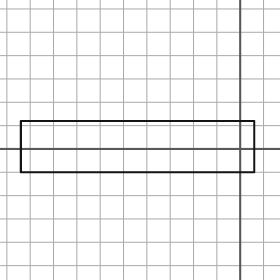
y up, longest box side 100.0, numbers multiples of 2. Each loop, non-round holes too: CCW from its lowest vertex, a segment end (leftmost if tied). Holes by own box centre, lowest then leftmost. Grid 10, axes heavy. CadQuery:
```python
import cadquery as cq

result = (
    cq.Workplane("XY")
    .moveTo(-94.0, -10.0)
    .lineTo(6.0, -10.0)
    .lineTo(6.0, 12.0)
    .lineTo(-94.0, 12.0)
    .close()
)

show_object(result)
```